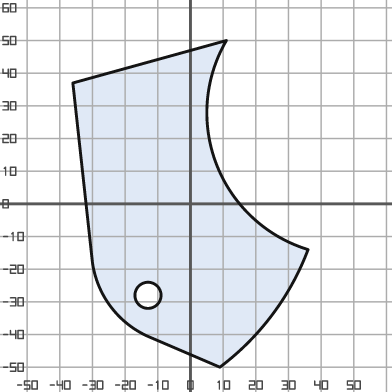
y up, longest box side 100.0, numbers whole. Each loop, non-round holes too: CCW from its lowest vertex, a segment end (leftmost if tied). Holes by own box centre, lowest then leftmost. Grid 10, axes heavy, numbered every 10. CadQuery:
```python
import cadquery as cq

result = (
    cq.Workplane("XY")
    .moveTo(9.0, -50.0)
    .threePointArc((25.0, -34.0), (36.0, -14.0))
    .threePointArc((8.0, 12.0), (11.0, 50.0))
    .lineTo(-36.0, 37.0)
    .lineTo(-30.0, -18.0)
    .threePointArc((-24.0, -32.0), (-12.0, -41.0))
    .close()
    .moveTo(-13.0, -28.0)
    .circle(4.0)
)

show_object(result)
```